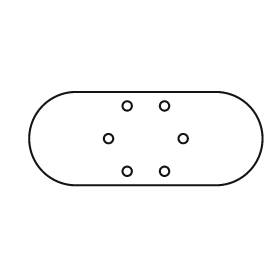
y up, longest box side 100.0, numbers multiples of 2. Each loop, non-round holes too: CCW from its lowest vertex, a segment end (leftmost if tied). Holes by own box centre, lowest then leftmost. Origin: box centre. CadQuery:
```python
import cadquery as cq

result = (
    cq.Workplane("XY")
    .moveTo(-30.0, -20.0)
    .lineTo(30.0, -20.0)
    .threePointArc((50.0, 0.0), (30.0, 20.0))
    .lineTo(-30.0, 20.0)
    .threePointArc((-50.0, 0.0), (-30.0, -20.0))
    .close()
    .moveTo(-8.0, -14.0)
    .circle(2.0)
    .moveTo(8.0, -14.0)
    .circle(2.0)
    .moveTo(-16.0, 0.0)
    .circle(2.0)
    .moveTo(16.0, 0.0)
    .circle(2.0)
    .moveTo(-8.0, 14.0)
    .circle(2.0)
    .moveTo(8.0, 14.0)
    .circle(2.0)
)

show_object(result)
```